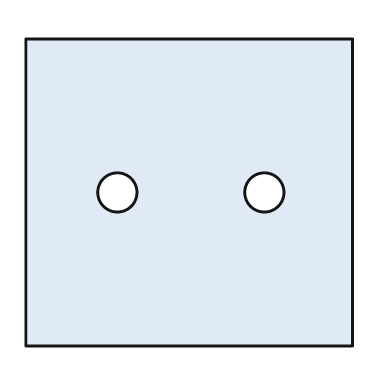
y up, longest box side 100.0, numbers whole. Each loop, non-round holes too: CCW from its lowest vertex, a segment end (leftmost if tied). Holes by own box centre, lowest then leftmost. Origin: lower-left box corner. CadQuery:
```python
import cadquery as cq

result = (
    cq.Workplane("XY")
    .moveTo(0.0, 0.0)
    .lineTo(100.0, 0.0)
    .lineTo(100.0, 94.0)
    .lineTo(0.0, 94.0)
    .close()
    .moveTo(28.0, 47.0)
    .circle(6.0)
    .moveTo(73.0, 47.0)
    .circle(6.0)
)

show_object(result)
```